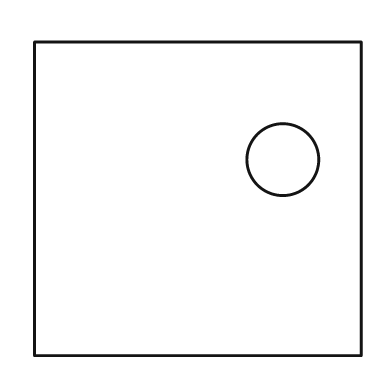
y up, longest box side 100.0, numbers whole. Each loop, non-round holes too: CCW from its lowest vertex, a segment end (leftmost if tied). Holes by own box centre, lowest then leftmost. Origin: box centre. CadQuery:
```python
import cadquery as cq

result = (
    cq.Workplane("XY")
    .moveTo(-50.0, -48.0)
    .lineTo(50.0, -48.0)
    .lineTo(50.0, 48.0)
    .lineTo(-50.0, 48.0)
    .close()
    .moveTo(26.0, 12.0)
    .circle(11.0)
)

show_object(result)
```